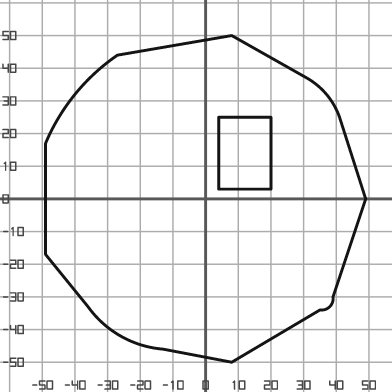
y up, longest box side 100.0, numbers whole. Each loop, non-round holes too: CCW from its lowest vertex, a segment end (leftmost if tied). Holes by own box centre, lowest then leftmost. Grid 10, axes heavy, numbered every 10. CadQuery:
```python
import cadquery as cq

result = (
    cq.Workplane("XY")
    .moveTo(8.0, -50.0)
    .lineTo(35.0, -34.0)
    .threePointArc((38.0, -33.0), (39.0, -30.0))
    .lineTo(49.0, 0.0)
    .lineTo(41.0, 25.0)
    .threePointArc((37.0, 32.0), (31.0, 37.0))
    .lineTo(8.0, 50.0)
    .lineTo(-27.0, 44.0)
    .threePointArc((-40.0, 32.0), (-49.0, 17.0))
    .lineTo(-49.0, -17.0)
    .lineTo(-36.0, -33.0)
    .threePointArc((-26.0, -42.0), (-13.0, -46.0))
    .close()
    .moveTo(4.0, 3.0)
    .lineTo(20.0, 3.0)
    .lineTo(20.0, 25.0)
    .lineTo(4.0, 25.0)
    .close()
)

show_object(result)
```